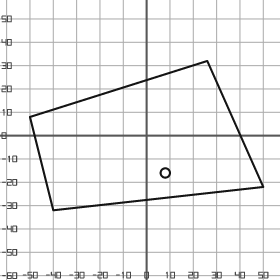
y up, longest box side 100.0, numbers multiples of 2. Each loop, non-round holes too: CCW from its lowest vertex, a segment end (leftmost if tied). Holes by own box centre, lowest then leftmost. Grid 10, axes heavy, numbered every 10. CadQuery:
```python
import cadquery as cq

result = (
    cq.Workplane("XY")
    .moveTo(-40.0, -32.0)
    .lineTo(50.0, -22.0)
    .lineTo(26.0, 32.0)
    .lineTo(-50.0, 8.0)
    .close()
    .moveTo(8.0, -16.0)
    .circle(2.0)
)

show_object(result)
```